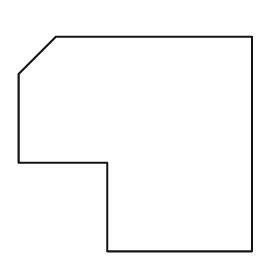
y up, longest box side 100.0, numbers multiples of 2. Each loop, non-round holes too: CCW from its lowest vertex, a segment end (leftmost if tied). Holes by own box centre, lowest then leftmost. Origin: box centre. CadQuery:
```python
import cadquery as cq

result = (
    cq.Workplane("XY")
    .moveTo(-12.0, -46.0)
    .lineTo(50.0, -46.0)
    .lineTo(50.0, 46.0)
    .lineTo(-34.0, 46.0)
    .lineTo(-50.0, 30.0)
    .lineTo(-50.0, -8.0)
    .lineTo(-12.0, -8.0)
    .close()
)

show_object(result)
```